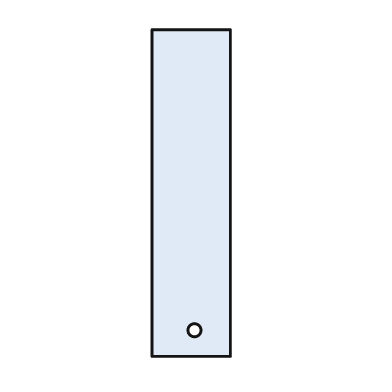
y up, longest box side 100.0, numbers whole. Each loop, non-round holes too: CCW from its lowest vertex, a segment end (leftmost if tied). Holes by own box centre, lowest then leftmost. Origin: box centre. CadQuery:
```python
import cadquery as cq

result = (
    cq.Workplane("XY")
    .moveTo(-12.0, -50.0)
    .lineTo(12.0, -50.0)
    .lineTo(12.0, 50.0)
    .lineTo(-12.0, 50.0)
    .close()
    .moveTo(1.0, -42.0)
    .circle(2.0)
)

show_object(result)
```